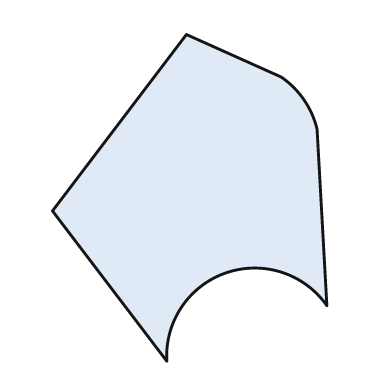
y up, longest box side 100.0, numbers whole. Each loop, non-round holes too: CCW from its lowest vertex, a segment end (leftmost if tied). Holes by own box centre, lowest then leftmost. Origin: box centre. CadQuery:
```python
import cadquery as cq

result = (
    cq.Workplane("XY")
    .moveTo(-7.0, -50.0)
    .threePointArc((11.0, -23.0), (42.0, -33.0))
    .lineTo(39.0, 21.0)
    .threePointArc((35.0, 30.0), (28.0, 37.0))
    .lineTo(-1.0, 50.0)
    .lineTo(-42.0, -4.0)
    .close()
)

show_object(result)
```